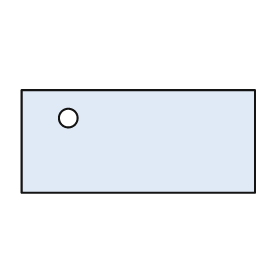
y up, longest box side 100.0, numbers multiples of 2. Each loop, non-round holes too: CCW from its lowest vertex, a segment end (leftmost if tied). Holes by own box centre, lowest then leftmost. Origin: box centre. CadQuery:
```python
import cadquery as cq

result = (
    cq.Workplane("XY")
    .moveTo(-50.0, -22.0)
    .lineTo(50.0, -22.0)
    .lineTo(50.0, 22.0)
    .lineTo(-50.0, 22.0)
    .close()
    .moveTo(-30.0, 10.0)
    .circle(4.0)
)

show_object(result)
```